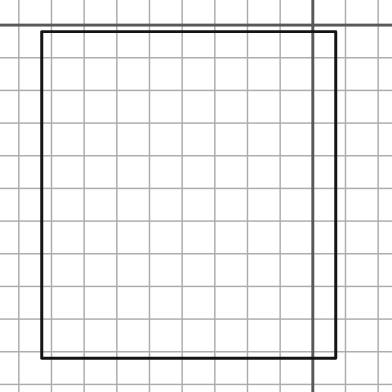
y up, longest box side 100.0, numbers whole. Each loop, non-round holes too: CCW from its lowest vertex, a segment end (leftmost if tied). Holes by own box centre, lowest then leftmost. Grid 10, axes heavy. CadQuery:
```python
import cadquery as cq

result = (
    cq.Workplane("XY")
    .moveTo(-83.0, -102.0)
    .lineTo(7.0, -102.0)
    .lineTo(7.0, -2.0)
    .lineTo(-83.0, -2.0)
    .close()
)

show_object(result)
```